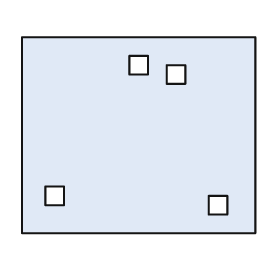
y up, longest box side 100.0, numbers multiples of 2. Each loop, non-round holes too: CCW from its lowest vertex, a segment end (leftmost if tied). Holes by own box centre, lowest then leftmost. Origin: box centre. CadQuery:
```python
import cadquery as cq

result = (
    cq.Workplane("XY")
    .moveTo(-50.0, -42.0)
    .lineTo(50.0, -42.0)
    .lineTo(50.0, 42.0)
    .lineTo(-50.0, 42.0)
    .close()
    .moveTo(30.0, -34.0)
    .lineTo(38.0, -34.0)
    .lineTo(38.0, -26.0)
    .lineTo(30.0, -26.0)
    .close()
    .moveTo(-40.0, -30.0)
    .lineTo(-32.0, -30.0)
    .lineTo(-32.0, -22.0)
    .lineTo(-40.0, -22.0)
    .close()
    .moveTo(12.0, 22.0)
    .lineTo(20.0, 22.0)
    .lineTo(20.0, 30.0)
    .lineTo(12.0, 30.0)
    .close()
    .moveTo(-4.0, 26.0)
    .lineTo(4.0, 26.0)
    .lineTo(4.0, 34.0)
    .lineTo(-4.0, 34.0)
    .close()
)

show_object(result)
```